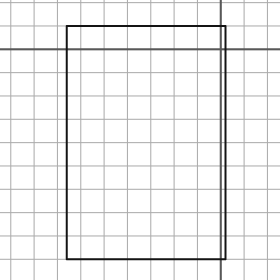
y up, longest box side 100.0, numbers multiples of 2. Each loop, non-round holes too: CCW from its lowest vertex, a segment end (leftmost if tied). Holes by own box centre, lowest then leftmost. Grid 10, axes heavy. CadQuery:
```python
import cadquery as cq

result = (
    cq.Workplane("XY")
    .moveTo(-66.0, -90.0)
    .lineTo(2.0, -90.0)
    .lineTo(2.0, 10.0)
    .lineTo(-66.0, 10.0)
    .close()
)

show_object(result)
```